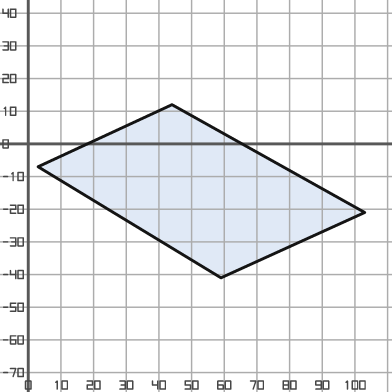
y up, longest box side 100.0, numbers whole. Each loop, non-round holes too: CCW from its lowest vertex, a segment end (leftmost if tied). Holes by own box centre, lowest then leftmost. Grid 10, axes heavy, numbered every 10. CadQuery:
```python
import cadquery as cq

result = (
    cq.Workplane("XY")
    .moveTo(59.0, -41.0)
    .lineTo(103.0, -21.0)
    .lineTo(44.0, 12.0)
    .lineTo(3.0, -7.0)
    .close()
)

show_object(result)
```